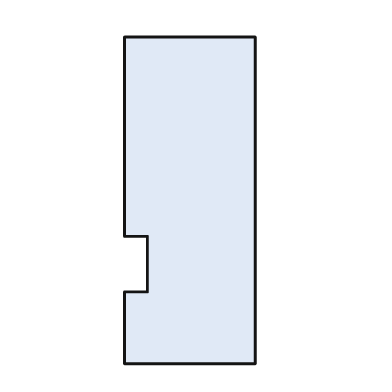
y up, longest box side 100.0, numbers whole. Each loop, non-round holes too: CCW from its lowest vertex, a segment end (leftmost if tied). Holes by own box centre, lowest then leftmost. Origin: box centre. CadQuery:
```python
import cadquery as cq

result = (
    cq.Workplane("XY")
    .moveTo(-20.0, -50.0)
    .lineTo(20.0, -50.0)
    .lineTo(20.0, 50.0)
    .lineTo(-20.0, 50.0)
    .lineTo(-20.0, -11.0)
    .lineTo(-13.0, -11.0)
    .lineTo(-13.0, -28.0)
    .lineTo(-20.0, -28.0)
    .close()
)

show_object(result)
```